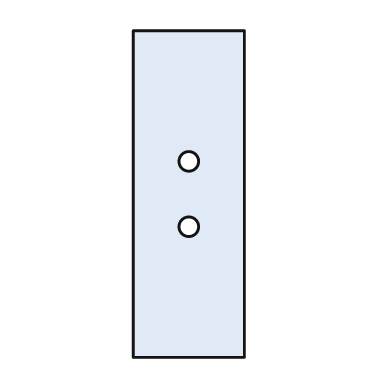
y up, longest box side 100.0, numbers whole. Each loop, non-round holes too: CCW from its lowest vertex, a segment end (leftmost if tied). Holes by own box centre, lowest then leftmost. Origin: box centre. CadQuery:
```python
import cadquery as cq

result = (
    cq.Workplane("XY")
    .moveTo(-17.0, -50.0)
    .lineTo(17.0, -50.0)
    .lineTo(17.0, 50.0)
    .lineTo(-17.0, 50.0)
    .close()
    .moveTo(0.0, -10.0)
    .circle(3.0)
    .moveTo(0.0, 10.0)
    .circle(3.0)
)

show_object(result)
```